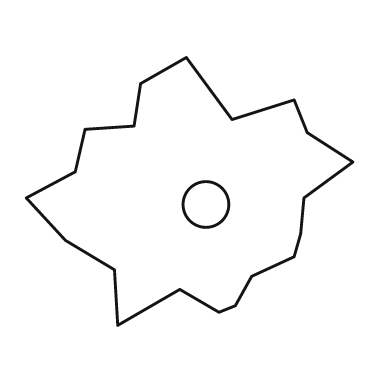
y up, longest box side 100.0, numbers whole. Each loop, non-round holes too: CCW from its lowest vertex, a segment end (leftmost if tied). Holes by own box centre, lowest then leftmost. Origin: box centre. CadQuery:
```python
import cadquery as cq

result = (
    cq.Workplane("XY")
    .moveTo(-22.0, -41.0)
    .lineTo(-3.0, -30.0)
    .lineTo(9.0, -37.0)
    .lineTo(14.0, -35.0)
    .lineTo(19.0, -26.0)
    .lineTo(32.0, -20.0)
    .lineTo(34.0, -13.0)
    .lineTo(35.0, -2.0)
    .lineTo(50.0, 9.0)
    .lineTo(36.0, 18.0)
    .lineTo(32.0, 28.0)
    .lineTo(13.0, 22.0)
    .lineTo(-1.0, 41.0)
    .lineTo(-15.0, 33.0)
    .lineTo(-17.0, 20.0)
    .lineTo(-32.0, 19.0)
    .lineTo(-35.0, 6.0)
    .lineTo(-50.0, -2.0)
    .lineTo(-38.0, -15.0)
    .lineTo(-23.0, -24.0)
    .close()
    .moveTo(5.0, -4.0)
    .circle(7.0)
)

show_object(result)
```